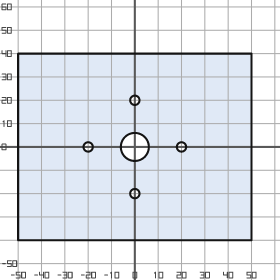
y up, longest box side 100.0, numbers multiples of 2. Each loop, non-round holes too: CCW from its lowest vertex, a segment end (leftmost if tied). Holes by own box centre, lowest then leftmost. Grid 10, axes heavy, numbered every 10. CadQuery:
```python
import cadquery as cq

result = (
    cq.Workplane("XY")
    .moveTo(-50.0, -40.0)
    .lineTo(50.0, -40.0)
    .lineTo(50.0, 40.0)
    .lineTo(-50.0, 40.0)
    .close()
    .moveTo(0.0, -20.0)
    .circle(2.0)
    .moveTo(-20.0, 0.0)
    .circle(2.0)
    .moveTo(0.0, 0.0)
    .circle(6.0)
    .moveTo(20.0, 0.0)
    .circle(2.0)
    .moveTo(0.0, 20.0)
    .circle(2.0)
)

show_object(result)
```